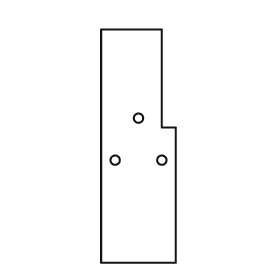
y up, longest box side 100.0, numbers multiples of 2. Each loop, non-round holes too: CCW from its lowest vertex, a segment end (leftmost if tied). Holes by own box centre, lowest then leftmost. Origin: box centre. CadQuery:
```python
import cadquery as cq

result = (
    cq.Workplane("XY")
    .moveTo(-16.0, -50.0)
    .lineTo(16.0, -50.0)
    .lineTo(16.0, 8.0)
    .lineTo(10.0, 8.0)
    .lineTo(10.0, 50.0)
    .lineTo(-16.0, 50.0)
    .close()
    .moveTo(-10.0, -6.0)
    .circle(2.0)
    .moveTo(10.0, -6.0)
    .circle(2.0)
    .moveTo(0.0, 12.0)
    .circle(2.0)
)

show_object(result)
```